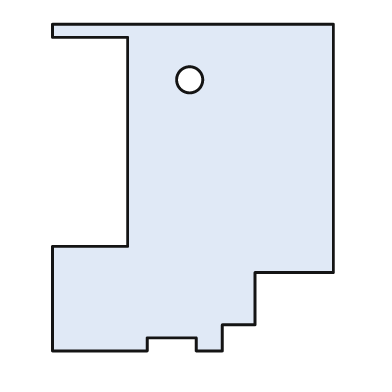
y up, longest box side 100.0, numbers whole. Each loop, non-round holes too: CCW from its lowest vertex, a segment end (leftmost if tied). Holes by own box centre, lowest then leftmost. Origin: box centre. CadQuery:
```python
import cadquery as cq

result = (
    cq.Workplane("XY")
    .moveTo(-43.0, -50.0)
    .lineTo(-14.0, -50.0)
    .lineTo(-14.0, -46.0)
    .lineTo(1.0, -46.0)
    .lineTo(1.0, -50.0)
    .lineTo(9.0, -50.0)
    .lineTo(9.0, -42.0)
    .lineTo(19.0, -42.0)
    .lineTo(19.0, -26.0)
    .lineTo(43.0, -26.0)
    .lineTo(43.0, 50.0)
    .lineTo(-43.0, 50.0)
    .lineTo(-43.0, 46.0)
    .lineTo(-20.0, 46.0)
    .lineTo(-20.0, -18.0)
    .lineTo(-43.0, -18.0)
    .close()
    .moveTo(-1.0, 33.0)
    .circle(4.0)
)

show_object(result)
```